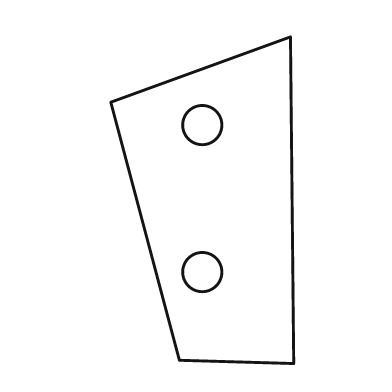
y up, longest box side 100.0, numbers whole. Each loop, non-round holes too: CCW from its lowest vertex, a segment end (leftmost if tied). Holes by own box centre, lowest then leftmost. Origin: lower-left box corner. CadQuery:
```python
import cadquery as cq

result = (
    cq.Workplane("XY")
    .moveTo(56.0, 0.0)
    .lineTo(55.0, 100.0)
    .lineTo(0.0, 80.0)
    .lineTo(21.0, 1.0)
    .close()
    .moveTo(28.0, 28.0)
    .circle(6.0)
    .moveTo(28.0, 73.0)
    .circle(6.0)
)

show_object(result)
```